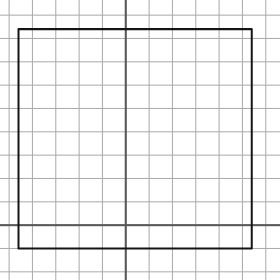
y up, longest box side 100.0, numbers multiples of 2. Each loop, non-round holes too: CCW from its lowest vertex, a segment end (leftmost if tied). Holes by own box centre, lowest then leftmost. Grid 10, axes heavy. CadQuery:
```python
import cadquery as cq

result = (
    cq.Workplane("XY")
    .moveTo(-46.0, -10.0)
    .lineTo(54.0, -10.0)
    .lineTo(54.0, 84.0)
    .lineTo(-46.0, 84.0)
    .close()
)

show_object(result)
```